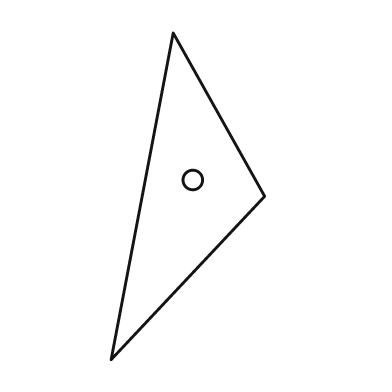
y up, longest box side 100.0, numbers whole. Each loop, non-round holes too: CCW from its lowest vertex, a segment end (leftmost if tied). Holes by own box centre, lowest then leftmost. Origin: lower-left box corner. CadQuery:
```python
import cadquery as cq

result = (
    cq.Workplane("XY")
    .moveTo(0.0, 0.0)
    .lineTo(47.0, 50.0)
    .lineTo(19.0, 100.0)
    .close()
    .moveTo(25.0, 55.0)
    .circle(3.0)
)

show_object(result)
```